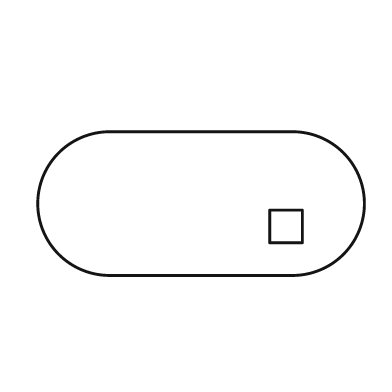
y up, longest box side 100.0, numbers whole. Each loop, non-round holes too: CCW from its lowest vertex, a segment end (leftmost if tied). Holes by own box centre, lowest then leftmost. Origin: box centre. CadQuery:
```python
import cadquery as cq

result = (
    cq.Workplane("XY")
    .moveTo(-28.0, -22.0)
    .lineTo(28.0, -22.0)
    .threePointArc((50.0, 0.0), (28.0, 22.0))
    .lineTo(-28.0, 22.0)
    .threePointArc((-50.0, 0.0), (-28.0, -22.0))
    .close()
    .moveTo(21.0, -12.0)
    .lineTo(31.0, -12.0)
    .lineTo(31.0, -2.0)
    .lineTo(21.0, -2.0)
    .close()
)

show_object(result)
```